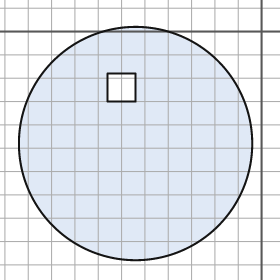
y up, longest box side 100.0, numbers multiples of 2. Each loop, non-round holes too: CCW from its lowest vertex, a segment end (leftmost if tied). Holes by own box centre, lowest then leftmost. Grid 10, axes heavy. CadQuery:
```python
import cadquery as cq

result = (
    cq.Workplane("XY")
    .moveTo(-54.0, -48.0)
    .circle(50.0)
    .moveTo(-66.0, -30.0)
    .lineTo(-54.0, -30.0)
    .lineTo(-54.0, -18.0)
    .lineTo(-66.0, -18.0)
    .close()
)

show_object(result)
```